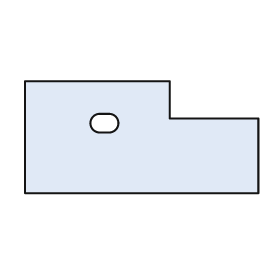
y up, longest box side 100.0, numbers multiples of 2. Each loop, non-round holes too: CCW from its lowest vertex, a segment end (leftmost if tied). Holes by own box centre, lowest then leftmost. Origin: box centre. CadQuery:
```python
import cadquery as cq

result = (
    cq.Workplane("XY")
    .moveTo(-50.0, -24.0)
    .lineTo(50.0, -24.0)
    .lineTo(50.0, 8.0)
    .lineTo(12.0, 8.0)
    .lineTo(12.0, 24.0)
    .lineTo(-50.0, 24.0)
    .close()
    .moveTo(-18.0, 2.0)
    .lineTo(-14.0, 2.0)
    .threePointArc((-10.0, 6.0), (-14.0, 10.0))
    .lineTo(-18.0, 10.0)
    .threePointArc((-22.0, 6.0), (-18.0, 2.0))
    .close()
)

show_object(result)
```